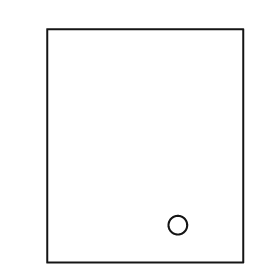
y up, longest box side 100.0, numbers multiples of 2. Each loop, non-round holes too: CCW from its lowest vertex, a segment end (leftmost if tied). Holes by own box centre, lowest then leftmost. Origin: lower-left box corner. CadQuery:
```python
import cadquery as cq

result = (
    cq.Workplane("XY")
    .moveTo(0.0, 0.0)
    .lineTo(84.0, 0.0)
    .lineTo(84.0, 100.0)
    .lineTo(0.0, 100.0)
    .close()
    .moveTo(56.0, 16.0)
    .circle(4.0)
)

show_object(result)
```